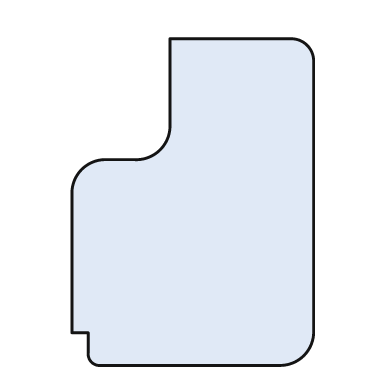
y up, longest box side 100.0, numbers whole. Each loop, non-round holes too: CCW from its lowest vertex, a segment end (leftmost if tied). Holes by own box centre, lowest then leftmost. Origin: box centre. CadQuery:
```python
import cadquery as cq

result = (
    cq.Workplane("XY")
    .moveTo(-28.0, -50.0)
    .lineTo(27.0, -50.0)
    .threePointArc((34.0, -47.0), (37.0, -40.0))
    .lineTo(37.0, 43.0)
    .threePointArc((35.0, 48.0), (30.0, 50.0))
    .lineTo(-7.0, 50.0)
    .lineTo(-7.0, 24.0)
    .threePointArc((-10.0, 16.0), (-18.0, 13.0))
    .lineTo(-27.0, 13.0)
    .threePointArc((-34.0, 10.0), (-37.0, 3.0))
    .lineTo(-37.0, -40.0)
    .lineTo(-32.0, -40.0)
    .lineTo(-32.0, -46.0)
    .threePointArc((-31.0, -49.0), (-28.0, -50.0))
    .close()
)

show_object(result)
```